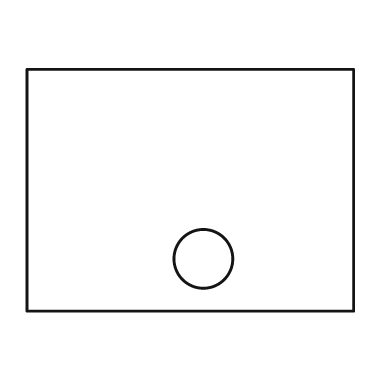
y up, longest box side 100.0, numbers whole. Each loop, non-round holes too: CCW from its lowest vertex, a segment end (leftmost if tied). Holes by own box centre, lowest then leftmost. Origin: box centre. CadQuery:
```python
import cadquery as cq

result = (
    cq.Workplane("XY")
    .moveTo(-50.0, -37.0)
    .lineTo(50.0, -37.0)
    .lineTo(50.0, 37.0)
    .lineTo(-50.0, 37.0)
    .close()
    .moveTo(4.0, -21.0)
    .circle(9.0)
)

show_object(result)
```